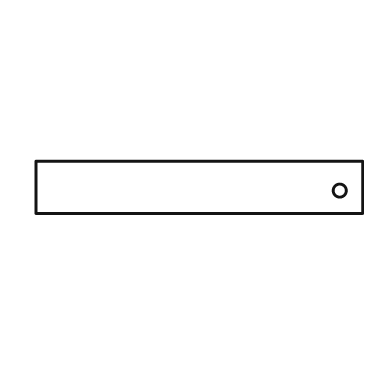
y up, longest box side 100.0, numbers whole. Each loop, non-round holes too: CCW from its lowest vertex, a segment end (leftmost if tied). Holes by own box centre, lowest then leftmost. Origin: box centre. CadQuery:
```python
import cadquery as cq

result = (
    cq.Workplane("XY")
    .moveTo(-50.0, -8.0)
    .lineTo(50.0, -8.0)
    .lineTo(50.0, 8.0)
    .lineTo(-50.0, 8.0)
    .close()
    .moveTo(43.0, -1.0)
    .circle(2.0)
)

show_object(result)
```